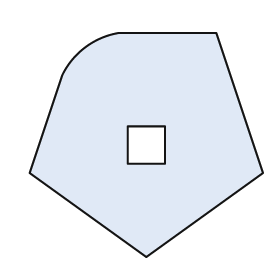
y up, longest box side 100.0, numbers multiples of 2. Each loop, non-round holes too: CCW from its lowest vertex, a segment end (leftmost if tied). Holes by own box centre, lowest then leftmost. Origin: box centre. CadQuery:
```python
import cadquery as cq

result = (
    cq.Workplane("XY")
    .moveTo(0.0, -48.0)
    .lineTo(50.0, -12.0)
    .lineTo(30.0, 48.0)
    .lineTo(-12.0, 48.0)
    .threePointArc((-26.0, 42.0), (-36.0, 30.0))
    .lineTo(-50.0, -12.0)
    .close()
    .moveTo(-8.0, -8.0)
    .lineTo(8.0, -8.0)
    .lineTo(8.0, 8.0)
    .lineTo(-8.0, 8.0)
    .close()
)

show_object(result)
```